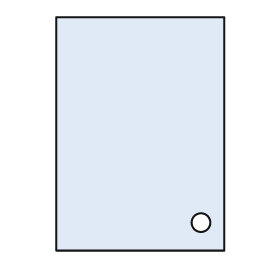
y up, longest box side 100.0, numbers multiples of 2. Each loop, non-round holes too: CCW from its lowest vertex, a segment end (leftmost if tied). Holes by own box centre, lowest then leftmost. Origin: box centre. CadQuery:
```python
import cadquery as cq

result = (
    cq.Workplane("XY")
    .moveTo(-36.0, -50.0)
    .lineTo(36.0, -50.0)
    .lineTo(36.0, 50.0)
    .lineTo(-36.0, 50.0)
    .close()
    .moveTo(26.0, -38.0)
    .circle(4.0)
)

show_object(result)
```